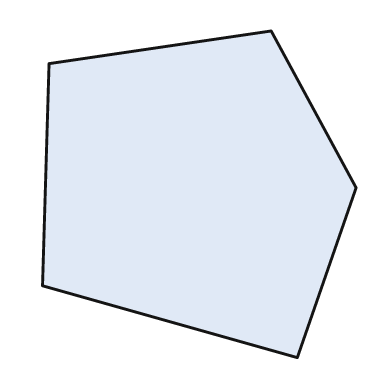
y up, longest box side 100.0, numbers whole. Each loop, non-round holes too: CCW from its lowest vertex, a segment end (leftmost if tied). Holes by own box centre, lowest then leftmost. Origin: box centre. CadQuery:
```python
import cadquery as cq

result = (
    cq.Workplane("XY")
    .moveTo(30.0, -50.0)
    .lineTo(48.0, 2.0)
    .lineTo(22.0, 50.0)
    .lineTo(-46.0, 40.0)
    .lineTo(-48.0, -28.0)
    .close()
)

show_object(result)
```